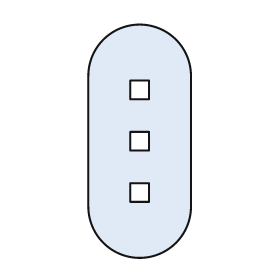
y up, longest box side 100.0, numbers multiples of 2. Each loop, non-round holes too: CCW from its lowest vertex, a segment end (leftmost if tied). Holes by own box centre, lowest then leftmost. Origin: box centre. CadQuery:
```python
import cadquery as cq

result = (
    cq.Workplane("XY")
    .moveTo(-22.0, -28.0)
    .threePointArc((0.0, -50.0), (22.0, -28.0))
    .lineTo(22.0, 28.0)
    .threePointArc((0.0, 50.0), (-22.0, 28.0))
    .close()
    .moveTo(-4.0, -26.0)
    .lineTo(4.0, -26.0)
    .lineTo(4.0, -18.0)
    .lineTo(-4.0, -18.0)
    .close()
    .moveTo(-4.0, -4.0)
    .lineTo(4.0, -4.0)
    .lineTo(4.0, 4.0)
    .lineTo(-4.0, 4.0)
    .close()
    .moveTo(-4.0, 18.0)
    .lineTo(4.0, 18.0)
    .lineTo(4.0, 26.0)
    .lineTo(-4.0, 26.0)
    .close()
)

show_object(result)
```